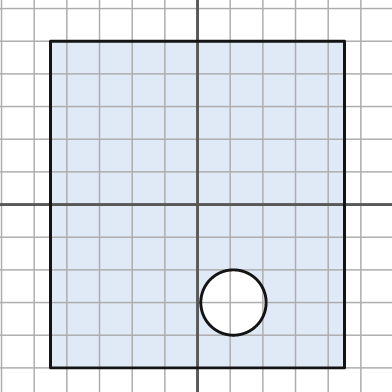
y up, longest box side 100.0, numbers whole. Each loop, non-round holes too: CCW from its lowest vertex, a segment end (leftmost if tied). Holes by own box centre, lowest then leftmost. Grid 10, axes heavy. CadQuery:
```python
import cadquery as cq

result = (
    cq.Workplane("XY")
    .moveTo(-45.0, -50.0)
    .lineTo(45.0, -50.0)
    .lineTo(45.0, 50.0)
    .lineTo(-45.0, 50.0)
    .close()
    .moveTo(11.0, -30.0)
    .circle(10.0)
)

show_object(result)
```